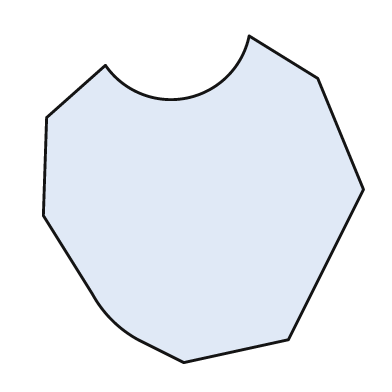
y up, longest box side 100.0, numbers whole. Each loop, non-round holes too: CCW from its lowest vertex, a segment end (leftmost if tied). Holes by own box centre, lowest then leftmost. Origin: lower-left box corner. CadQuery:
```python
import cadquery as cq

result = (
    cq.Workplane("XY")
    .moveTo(43.0, 0.0)
    .lineTo(75.0, 7.0)
    .lineTo(98.0, 53.0)
    .lineTo(84.0, 87.0)
    .lineTo(63.0, 100.0)
    .threePointArc((44.0, 81.0), (19.0, 91.0))
    .lineTo(1.0, 75.0)
    .lineTo(0.0, 45.0)
    .lineTo(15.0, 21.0)
    .threePointArc((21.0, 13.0), (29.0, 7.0))
    .close()
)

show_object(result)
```